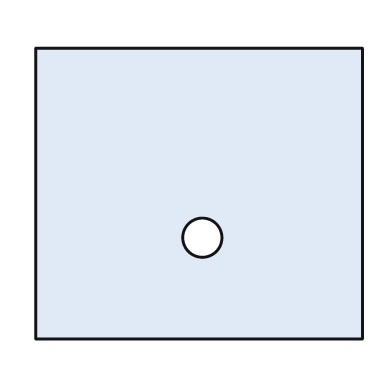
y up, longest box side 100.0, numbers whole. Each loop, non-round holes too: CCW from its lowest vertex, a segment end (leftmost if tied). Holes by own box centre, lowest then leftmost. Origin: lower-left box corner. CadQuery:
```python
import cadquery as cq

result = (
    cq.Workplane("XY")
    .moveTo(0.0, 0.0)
    .lineTo(100.0, 0.0)
    .lineTo(100.0, 89.0)
    .lineTo(0.0, 89.0)
    .close()
    .moveTo(51.0, 31.0)
    .circle(6.0)
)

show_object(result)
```